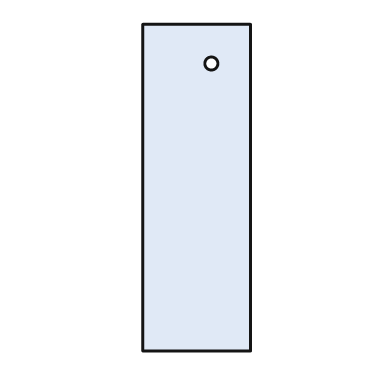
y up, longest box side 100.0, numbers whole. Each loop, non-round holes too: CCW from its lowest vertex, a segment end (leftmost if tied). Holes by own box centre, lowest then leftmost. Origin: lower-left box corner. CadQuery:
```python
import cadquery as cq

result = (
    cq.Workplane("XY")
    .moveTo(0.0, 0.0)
    .lineTo(33.0, 0.0)
    .lineTo(33.0, 100.0)
    .lineTo(0.0, 100.0)
    .close()
    .moveTo(21.0, 88.0)
    .circle(2.0)
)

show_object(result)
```